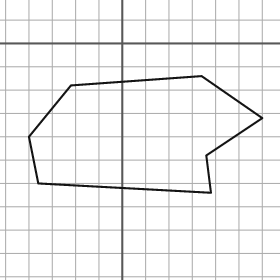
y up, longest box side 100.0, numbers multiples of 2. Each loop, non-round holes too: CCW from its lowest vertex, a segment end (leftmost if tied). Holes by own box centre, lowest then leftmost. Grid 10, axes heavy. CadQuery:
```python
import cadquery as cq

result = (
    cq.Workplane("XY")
    .moveTo(38.0, -64.0)
    .lineTo(36.0, -48.0)
    .lineTo(60.0, -32.0)
    .lineTo(34.0, -14.0)
    .lineTo(-22.0, -18.0)
    .lineTo(-40.0, -40.0)
    .lineTo(-36.0, -60.0)
    .close()
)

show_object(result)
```